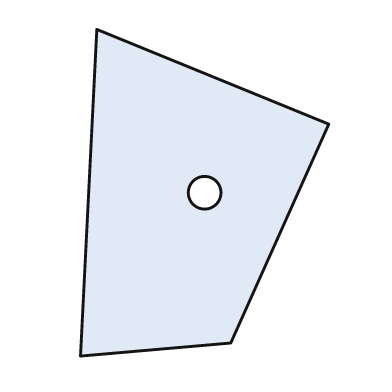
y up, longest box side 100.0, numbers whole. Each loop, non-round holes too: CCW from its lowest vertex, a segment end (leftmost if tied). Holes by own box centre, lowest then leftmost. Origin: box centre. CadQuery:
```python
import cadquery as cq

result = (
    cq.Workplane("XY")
    .moveTo(-38.0, -50.0)
    .lineTo(8.0, -46.0)
    .lineTo(38.0, 21.0)
    .lineTo(-33.0, 50.0)
    .close()
    .moveTo(0.0, 0.0)
    .circle(5.0)
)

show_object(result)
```